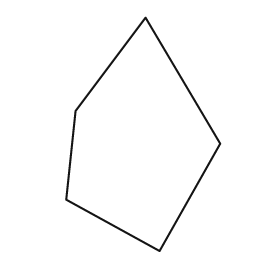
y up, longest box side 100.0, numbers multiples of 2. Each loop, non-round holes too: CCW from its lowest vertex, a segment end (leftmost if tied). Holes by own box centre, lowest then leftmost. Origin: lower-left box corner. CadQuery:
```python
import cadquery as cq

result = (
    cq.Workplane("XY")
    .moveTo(40.0, 0.0)
    .lineTo(66.0, 46.0)
    .lineTo(34.0, 100.0)
    .lineTo(4.0, 60.0)
    .lineTo(0.0, 22.0)
    .close()
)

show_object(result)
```